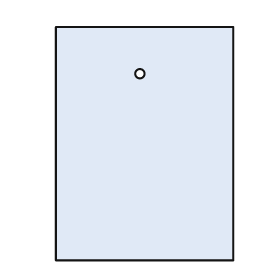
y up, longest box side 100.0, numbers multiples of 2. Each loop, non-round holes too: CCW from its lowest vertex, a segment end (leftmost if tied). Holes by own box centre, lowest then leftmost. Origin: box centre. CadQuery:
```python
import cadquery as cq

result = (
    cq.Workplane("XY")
    .moveTo(-38.0, -50.0)
    .lineTo(38.0, -50.0)
    .lineTo(38.0, 50.0)
    .lineTo(-38.0, 50.0)
    .close()
    .moveTo(-2.0, 30.0)
    .circle(2.0)
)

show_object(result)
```